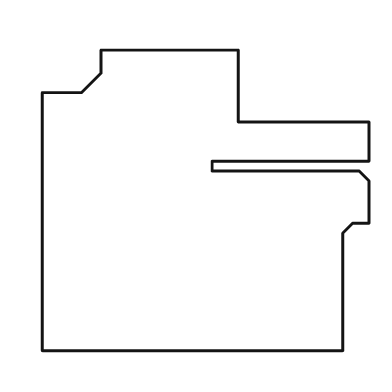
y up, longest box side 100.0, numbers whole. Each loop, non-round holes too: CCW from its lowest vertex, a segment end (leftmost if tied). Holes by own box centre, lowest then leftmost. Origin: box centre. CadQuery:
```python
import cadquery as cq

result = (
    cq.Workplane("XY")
    .moveTo(-50.0, -46.0)
    .lineTo(42.0, -46.0)
    .lineTo(42.0, -10.0)
    .lineTo(45.0, -7.0)
    .lineTo(50.0, -7.0)
    .lineTo(50.0, 6.0)
    .lineTo(47.0, 9.0)
    .lineTo(2.0, 9.0)
    .lineTo(2.0, 12.0)
    .lineTo(50.0, 12.0)
    .lineTo(50.0, 24.0)
    .lineTo(10.0, 24.0)
    .lineTo(10.0, 46.0)
    .lineTo(-32.0, 46.0)
    .lineTo(-32.0, 39.0)
    .lineTo(-38.0, 33.0)
    .lineTo(-50.0, 33.0)
    .close()
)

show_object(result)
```